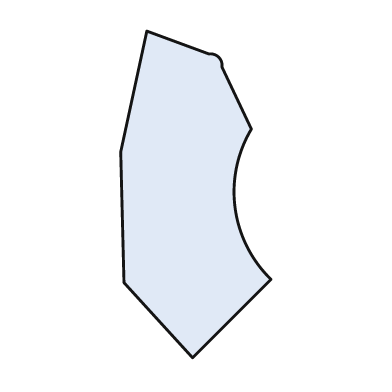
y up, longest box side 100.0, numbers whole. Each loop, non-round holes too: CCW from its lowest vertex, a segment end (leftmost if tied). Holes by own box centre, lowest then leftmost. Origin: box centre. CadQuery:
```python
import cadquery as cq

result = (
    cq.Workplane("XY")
    .moveTo(-1.0, -50.0)
    .lineTo(23.0, -26.0)
    .threePointArc((12.0, -4.0), (17.0, 20.0))
    .lineTo(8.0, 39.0)
    .threePointArc((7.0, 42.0), (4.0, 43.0))
    .lineTo(-15.0, 50.0)
    .lineTo(-23.0, 13.0)
    .lineTo(-22.0, -27.0)
    .close()
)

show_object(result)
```